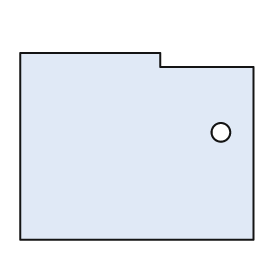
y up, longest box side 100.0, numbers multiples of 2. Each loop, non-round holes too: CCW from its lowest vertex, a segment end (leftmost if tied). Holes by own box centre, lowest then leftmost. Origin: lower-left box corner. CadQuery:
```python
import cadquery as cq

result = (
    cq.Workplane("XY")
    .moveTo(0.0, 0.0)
    .lineTo(100.0, 0.0)
    .lineTo(100.0, 74.0)
    .lineTo(60.0, 74.0)
    .lineTo(60.0, 80.0)
    .lineTo(0.0, 80.0)
    .close()
    .moveTo(86.0, 46.0)
    .circle(4.0)
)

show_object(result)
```